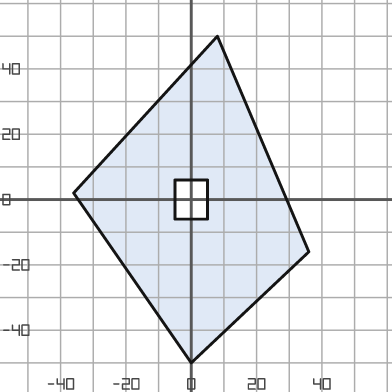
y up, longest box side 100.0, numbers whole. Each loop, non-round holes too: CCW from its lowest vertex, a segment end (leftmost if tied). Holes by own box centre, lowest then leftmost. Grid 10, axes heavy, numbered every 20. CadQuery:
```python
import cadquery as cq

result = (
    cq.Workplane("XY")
    .moveTo(0.0, -50.0)
    .lineTo(36.0, -16.0)
    .lineTo(8.0, 50.0)
    .lineTo(-36.0, 2.0)
    .close()
    .moveTo(-5.0, -6.0)
    .lineTo(5.0, -6.0)
    .lineTo(5.0, 6.0)
    .lineTo(-5.0, 6.0)
    .close()
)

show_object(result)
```